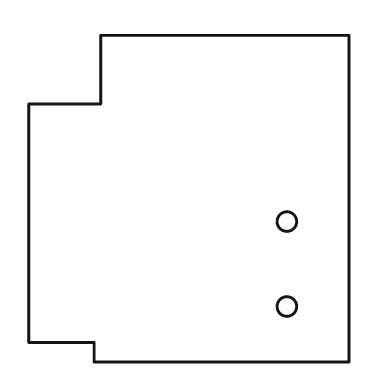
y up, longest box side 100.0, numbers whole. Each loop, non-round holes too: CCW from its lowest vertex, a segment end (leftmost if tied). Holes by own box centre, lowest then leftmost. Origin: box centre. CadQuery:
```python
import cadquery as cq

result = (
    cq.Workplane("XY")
    .moveTo(-29.0, -50.0)
    .lineTo(49.0, -50.0)
    .lineTo(49.0, 50.0)
    .lineTo(-27.0, 50.0)
    .lineTo(-27.0, 29.0)
    .lineTo(-49.0, 29.0)
    .lineTo(-49.0, -44.0)
    .lineTo(-29.0, -44.0)
    .close()
    .moveTo(30.0, -33.0)
    .circle(3.0)
    .moveTo(30.0, -7.0)
    .circle(3.0)
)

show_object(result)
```